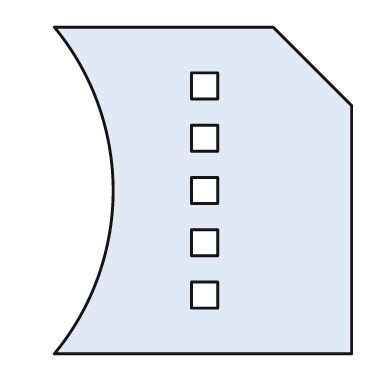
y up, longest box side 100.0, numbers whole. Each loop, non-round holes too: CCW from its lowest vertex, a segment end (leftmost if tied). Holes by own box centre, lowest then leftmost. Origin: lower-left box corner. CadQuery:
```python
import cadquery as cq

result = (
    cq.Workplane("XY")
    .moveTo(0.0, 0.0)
    .lineTo(91.0, 0.0)
    .lineTo(91.0, 76.0)
    .lineTo(67.0, 100.0)
    .lineTo(0.0, 100.0)
    .threePointArc((18.0, 50.0), (0.0, 0.0))
    .close()
    .moveTo(42.0, 14.0)
    .lineTo(50.0, 14.0)
    .lineTo(50.0, 22.0)
    .lineTo(42.0, 22.0)
    .close()
    .moveTo(42.0, 30.0)
    .lineTo(50.0, 30.0)
    .lineTo(50.0, 38.0)
    .lineTo(42.0, 38.0)
    .close()
    .moveTo(42.0, 46.0)
    .lineTo(50.0, 46.0)
    .lineTo(50.0, 54.0)
    .lineTo(42.0, 54.0)
    .close()
    .moveTo(42.0, 62.0)
    .lineTo(50.0, 62.0)
    .lineTo(50.0, 70.0)
    .lineTo(42.0, 70.0)
    .close()
    .moveTo(42.0, 78.0)
    .lineTo(50.0, 78.0)
    .lineTo(50.0, 86.0)
    .lineTo(42.0, 86.0)
    .close()
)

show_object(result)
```